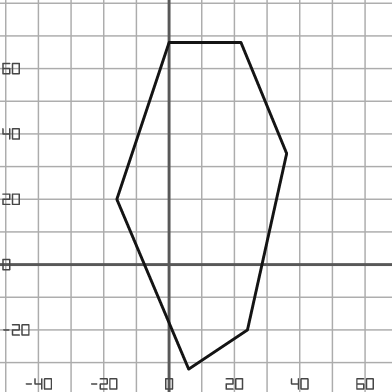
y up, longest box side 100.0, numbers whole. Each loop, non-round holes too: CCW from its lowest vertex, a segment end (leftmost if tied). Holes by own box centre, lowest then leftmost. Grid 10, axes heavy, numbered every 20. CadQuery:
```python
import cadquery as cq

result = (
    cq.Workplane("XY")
    .moveTo(6.0, -32.0)
    .lineTo(24.0, -20.0)
    .lineTo(36.0, 34.0)
    .lineTo(22.0, 68.0)
    .lineTo(0.0, 68.0)
    .lineTo(-16.0, 20.0)
    .close()
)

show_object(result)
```